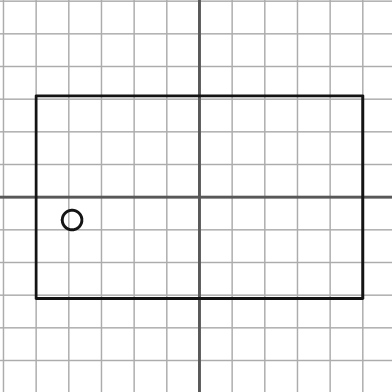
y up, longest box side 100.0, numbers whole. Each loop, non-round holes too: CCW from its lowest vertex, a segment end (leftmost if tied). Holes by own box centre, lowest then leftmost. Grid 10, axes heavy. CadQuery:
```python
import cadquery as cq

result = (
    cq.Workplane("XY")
    .moveTo(-50.0, -31.0)
    .lineTo(50.0, -31.0)
    .lineTo(50.0, 31.0)
    .lineTo(-50.0, 31.0)
    .close()
    .moveTo(-39.0, -7.0)
    .circle(3.0)
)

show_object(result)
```